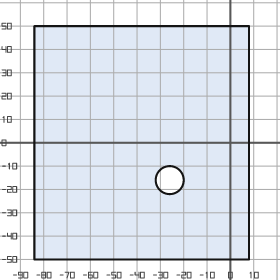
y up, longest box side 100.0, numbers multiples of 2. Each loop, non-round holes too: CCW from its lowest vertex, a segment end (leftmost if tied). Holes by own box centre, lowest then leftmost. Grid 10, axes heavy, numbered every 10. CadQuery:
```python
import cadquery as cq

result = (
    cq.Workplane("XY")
    .moveTo(-84.0, -50.0)
    .lineTo(8.0, -50.0)
    .lineTo(8.0, 50.0)
    .lineTo(-84.0, 50.0)
    .close()
    .moveTo(-26.0, -16.0)
    .circle(6.0)
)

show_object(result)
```